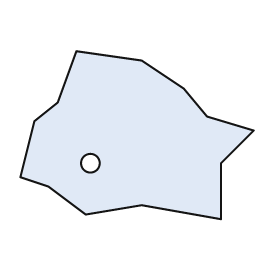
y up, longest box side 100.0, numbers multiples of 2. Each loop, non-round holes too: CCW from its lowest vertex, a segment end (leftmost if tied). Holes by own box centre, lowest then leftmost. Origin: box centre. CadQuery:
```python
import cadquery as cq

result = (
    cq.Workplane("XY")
    .moveTo(36.0, -36.0)
    .lineTo(36.0, -12.0)
    .lineTo(50.0, 2.0)
    .lineTo(30.0, 8.0)
    .lineTo(20.0, 20.0)
    .lineTo(2.0, 32.0)
    .lineTo(-26.0, 36.0)
    .lineTo(-34.0, 14.0)
    .lineTo(-44.0, 6.0)
    .lineTo(-50.0, -18.0)
    .lineTo(-38.0, -22.0)
    .lineTo(-22.0, -34.0)
    .lineTo(2.0, -30.0)
    .close()
    .moveTo(-20.0, -12.0)
    .circle(4.0)
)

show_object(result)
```